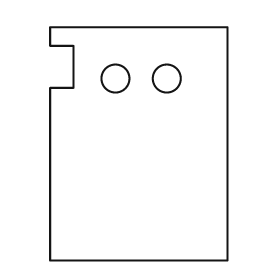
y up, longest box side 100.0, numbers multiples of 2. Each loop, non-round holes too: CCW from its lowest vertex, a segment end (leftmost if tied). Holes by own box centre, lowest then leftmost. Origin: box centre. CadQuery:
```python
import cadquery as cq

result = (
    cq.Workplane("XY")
    .moveTo(-38.0, -50.0)
    .lineTo(38.0, -50.0)
    .lineTo(38.0, 50.0)
    .lineTo(-38.0, 50.0)
    .lineTo(-38.0, 42.0)
    .lineTo(-28.0, 42.0)
    .lineTo(-28.0, 24.0)
    .lineTo(-38.0, 24.0)
    .close()
    .moveTo(-10.0, 28.0)
    .circle(6.0)
    .moveTo(12.0, 28.0)
    .circle(6.0)
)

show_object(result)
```